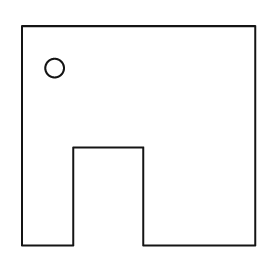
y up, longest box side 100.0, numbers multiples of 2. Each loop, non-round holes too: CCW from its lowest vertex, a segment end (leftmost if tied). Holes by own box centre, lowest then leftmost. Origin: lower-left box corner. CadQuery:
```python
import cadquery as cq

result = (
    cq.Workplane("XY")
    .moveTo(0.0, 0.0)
    .lineTo(22.0, 0.0)
    .lineTo(22.0, 42.0)
    .lineTo(52.0, 42.0)
    .lineTo(52.0, 0.0)
    .lineTo(100.0, 0.0)
    .lineTo(100.0, 94.0)
    .lineTo(0.0, 94.0)
    .close()
    .moveTo(14.0, 76.0)
    .circle(4.0)
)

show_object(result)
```